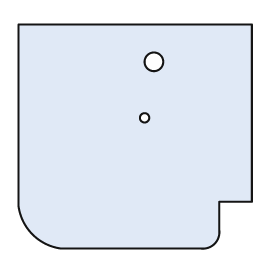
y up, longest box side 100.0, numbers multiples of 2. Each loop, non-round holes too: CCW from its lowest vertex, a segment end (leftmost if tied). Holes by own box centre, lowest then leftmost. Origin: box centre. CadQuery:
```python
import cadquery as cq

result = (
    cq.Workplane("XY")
    .moveTo(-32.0, -48.0)
    .lineTo(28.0, -48.0)
    .threePointArc((34.0, -46.0), (36.0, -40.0))
    .lineTo(36.0, -28.0)
    .lineTo(50.0, -28.0)
    .lineTo(50.0, 48.0)
    .lineTo(-50.0, 48.0)
    .lineTo(-50.0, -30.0)
    .threePointArc((-44.0, -42.0), (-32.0, -48.0))
    .close()
    .moveTo(4.0, 8.0)
    .circle(2.0)
    .moveTo(8.0, 32.0)
    .circle(4.0)
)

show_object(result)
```